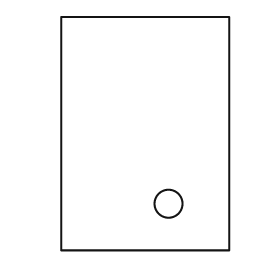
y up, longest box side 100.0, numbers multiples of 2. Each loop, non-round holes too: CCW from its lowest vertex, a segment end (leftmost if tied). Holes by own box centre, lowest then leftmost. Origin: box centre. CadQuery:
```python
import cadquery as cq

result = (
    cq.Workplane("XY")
    .moveTo(-36.0, -50.0)
    .lineTo(36.0, -50.0)
    .lineTo(36.0, 50.0)
    .lineTo(-36.0, 50.0)
    .close()
    .moveTo(10.0, -30.0)
    .circle(6.0)
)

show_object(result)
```